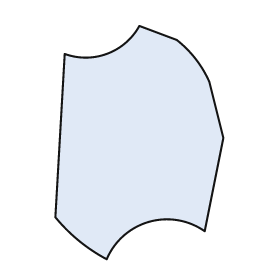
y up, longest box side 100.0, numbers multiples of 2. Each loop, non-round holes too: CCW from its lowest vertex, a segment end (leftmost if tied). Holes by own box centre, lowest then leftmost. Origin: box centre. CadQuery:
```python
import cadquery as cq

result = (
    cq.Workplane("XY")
    .moveTo(-14.0, -50.0)
    .threePointArc((4.0, -34.0), (28.0, -38.0))
    .lineTo(36.0, 2.0)
    .lineTo(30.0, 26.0)
    .threePointArc((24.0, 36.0), (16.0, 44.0))
    .lineTo(0.0, 50.0)
    .threePointArc((-14.0, 38.0), (-32.0, 38.0))
    .lineTo(-36.0, -32.0)
    .threePointArc((-26.0, -42.0), (-14.0, -50.0))
    .close()
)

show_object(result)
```